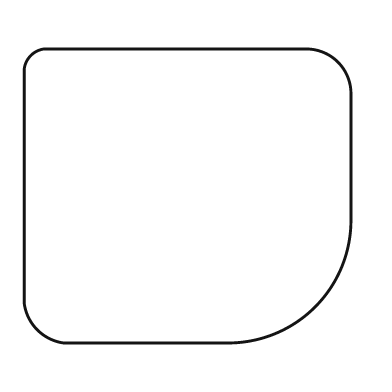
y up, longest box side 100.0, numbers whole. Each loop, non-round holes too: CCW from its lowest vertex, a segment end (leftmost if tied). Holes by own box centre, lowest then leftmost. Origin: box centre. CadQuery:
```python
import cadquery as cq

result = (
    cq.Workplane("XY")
    .moveTo(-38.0, -45.0)
    .lineTo(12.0, -45.0)
    .threePointArc((39.0, -34.0), (50.0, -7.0))
    .lineTo(50.0, 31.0)
    .threePointArc((46.0, 41.0), (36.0, 45.0))
    .lineTo(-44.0, 45.0)
    .threePointArc((-48.0, 43.0), (-50.0, 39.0))
    .lineTo(-50.0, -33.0)
    .threePointArc((-46.0, -41.0), (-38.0, -45.0))
    .close()
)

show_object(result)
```